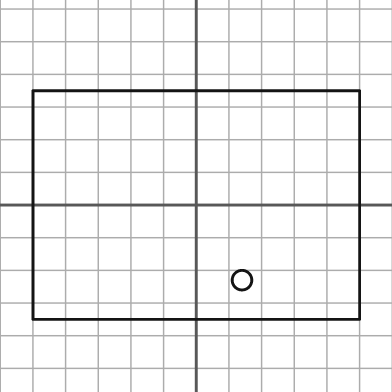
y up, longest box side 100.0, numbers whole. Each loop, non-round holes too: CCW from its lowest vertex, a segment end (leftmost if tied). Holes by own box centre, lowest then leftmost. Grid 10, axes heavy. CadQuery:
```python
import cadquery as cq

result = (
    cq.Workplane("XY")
    .moveTo(-50.0, -35.0)
    .lineTo(50.0, -35.0)
    .lineTo(50.0, 35.0)
    .lineTo(-50.0, 35.0)
    .close()
    .moveTo(14.0, -23.0)
    .circle(3.0)
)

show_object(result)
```